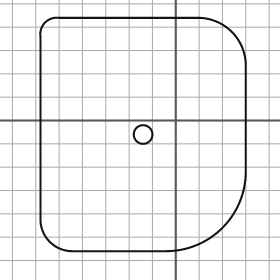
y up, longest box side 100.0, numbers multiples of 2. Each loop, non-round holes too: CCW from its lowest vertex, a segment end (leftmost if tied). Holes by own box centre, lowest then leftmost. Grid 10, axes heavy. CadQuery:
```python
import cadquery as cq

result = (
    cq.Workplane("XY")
    .moveTo(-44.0, -56.0)
    .lineTo(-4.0, -56.0)
    .threePointArc((20.0, -46.0), (30.0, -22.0))
    .lineTo(30.0, 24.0)
    .threePointArc((24.0, 38.0), (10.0, 44.0))
    .lineTo(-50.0, 44.0)
    .threePointArc((-56.0, 42.0), (-58.0, 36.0))
    .lineTo(-58.0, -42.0)
    .threePointArc((-54.0, -52.0), (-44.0, -56.0))
    .close()
    .moveTo(-14.0, -6.0)
    .circle(4.0)
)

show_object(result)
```